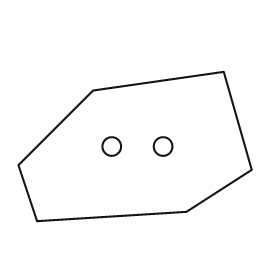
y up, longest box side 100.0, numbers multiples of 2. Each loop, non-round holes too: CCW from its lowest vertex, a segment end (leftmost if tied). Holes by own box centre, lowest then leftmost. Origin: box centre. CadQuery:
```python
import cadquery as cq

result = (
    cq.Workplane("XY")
    .moveTo(-42.0, -32.0)
    .lineTo(22.0, -28.0)
    .lineTo(50.0, -10.0)
    .lineTo(38.0, 32.0)
    .lineTo(-18.0, 24.0)
    .lineTo(-50.0, -8.0)
    .close()
    .moveTo(-10.0, 0.0)
    .circle(4.0)
    .moveTo(12.0, 0.0)
    .circle(4.0)
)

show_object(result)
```